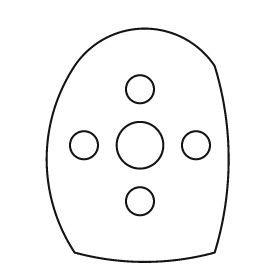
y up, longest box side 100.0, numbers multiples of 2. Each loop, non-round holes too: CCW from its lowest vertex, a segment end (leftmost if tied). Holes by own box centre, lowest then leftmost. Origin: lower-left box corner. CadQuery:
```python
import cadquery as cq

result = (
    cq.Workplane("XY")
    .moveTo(12.0, 4.0)
    .threePointArc((42.0, 0.0), (72.0, 4.0))
    .threePointArc((78.0, 44.0), (72.0, 84.0))
    .threePointArc((42.0, 100.0), (12.0, 84.0))
    .threePointArc((0.0, 44.0), (12.0, 4.0))
    .close()
    .moveTo(40.0, 26.0)
    .circle(6.0)
    .moveTo(16.0, 50.0)
    .circle(6.0)
    .moveTo(40.0, 50.0)
    .circle(10.0)
    .moveTo(64.0, 50.0)
    .circle(6.0)
    .moveTo(40.0, 74.0)
    .circle(6.0)
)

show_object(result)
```